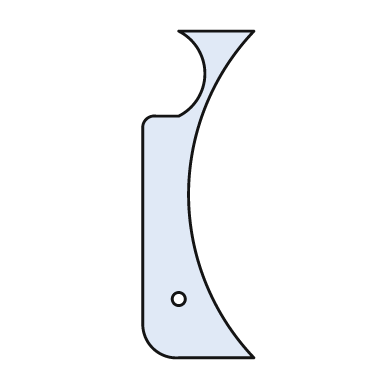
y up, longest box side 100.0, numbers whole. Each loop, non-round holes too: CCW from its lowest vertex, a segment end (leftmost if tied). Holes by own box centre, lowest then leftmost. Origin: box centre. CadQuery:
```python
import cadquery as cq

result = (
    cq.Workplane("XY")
    .moveTo(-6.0, -50.0)
    .lineTo(17.0, -50.0)
    .threePointArc((-3.0, 0.0), (17.0, 50.0))
    .lineTo(-6.0, 50.0)
    .threePointArc((2.0, 37.0), (-6.0, 24.0))
    .lineTo(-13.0, 24.0)
    .threePointArc((-16.0, 23.0), (-17.0, 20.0))
    .lineTo(-17.0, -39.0)
    .threePointArc((-14.0, -47.0), (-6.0, -50.0))
    .close()
    .moveTo(-6.0, -32.0)
    .circle(2.0)
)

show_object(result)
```